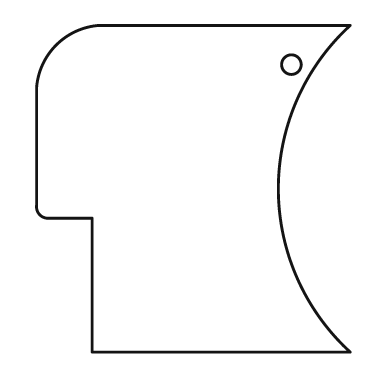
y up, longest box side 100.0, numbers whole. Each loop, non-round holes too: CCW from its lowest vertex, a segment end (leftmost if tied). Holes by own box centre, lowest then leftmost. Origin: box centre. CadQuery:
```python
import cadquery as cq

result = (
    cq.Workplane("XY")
    .moveTo(-31.0, -50.0)
    .lineTo(48.0, -50.0)
    .threePointArc((26.0, 0.0), (48.0, 50.0))
    .lineTo(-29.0, 50.0)
    .threePointArc((-42.0, 44.0), (-48.0, 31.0))
    .lineTo(-48.0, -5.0)
    .threePointArc((-47.0, -8.0), (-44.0, -9.0))
    .lineTo(-31.0, -9.0)
    .close()
    .moveTo(30.0, 38.0)
    .circle(3.0)
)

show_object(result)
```